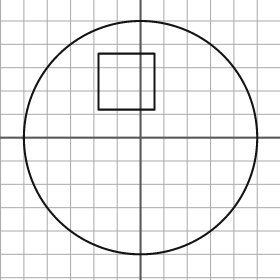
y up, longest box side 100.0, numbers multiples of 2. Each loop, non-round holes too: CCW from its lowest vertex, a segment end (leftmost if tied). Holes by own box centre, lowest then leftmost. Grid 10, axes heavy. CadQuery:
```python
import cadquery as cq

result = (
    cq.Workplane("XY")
    .moveTo(0.0, 0.0)
    .circle(50.0)
    .moveTo(-18.0, 12.0)
    .lineTo(6.0, 12.0)
    .lineTo(6.0, 36.0)
    .lineTo(-18.0, 36.0)
    .close()
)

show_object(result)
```